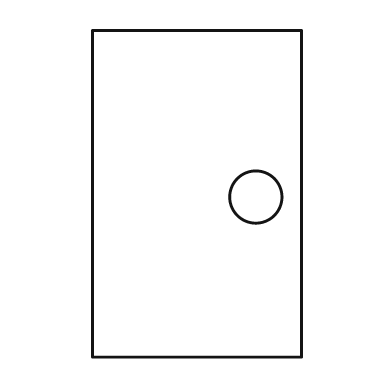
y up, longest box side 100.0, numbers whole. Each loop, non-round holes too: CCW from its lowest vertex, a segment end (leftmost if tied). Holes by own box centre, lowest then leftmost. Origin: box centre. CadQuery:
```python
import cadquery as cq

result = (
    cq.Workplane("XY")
    .moveTo(-32.0, -50.0)
    .lineTo(32.0, -50.0)
    .lineTo(32.0, 50.0)
    .lineTo(-32.0, 50.0)
    .close()
    .moveTo(18.0, -1.0)
    .circle(8.0)
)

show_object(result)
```